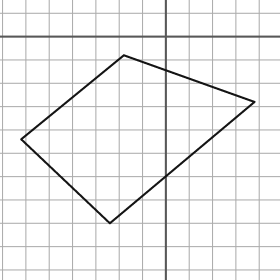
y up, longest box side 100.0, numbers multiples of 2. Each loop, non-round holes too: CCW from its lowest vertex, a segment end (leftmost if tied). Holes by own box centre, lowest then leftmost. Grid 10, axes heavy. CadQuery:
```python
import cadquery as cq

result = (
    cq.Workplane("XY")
    .moveTo(-24.0, -80.0)
    .lineTo(38.0, -28.0)
    .lineTo(-18.0, -8.0)
    .lineTo(-62.0, -44.0)
    .close()
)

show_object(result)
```